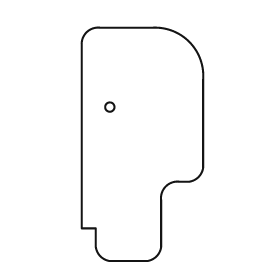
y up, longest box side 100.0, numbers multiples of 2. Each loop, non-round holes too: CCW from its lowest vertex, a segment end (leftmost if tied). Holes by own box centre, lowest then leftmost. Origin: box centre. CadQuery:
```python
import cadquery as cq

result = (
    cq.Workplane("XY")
    .moveTo(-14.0, -50.0)
    .lineTo(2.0, -50.0)
    .threePointArc((6.0, -48.0), (8.0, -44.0))
    .lineTo(8.0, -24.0)
    .threePointArc((10.0, -18.0), (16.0, -16.0))
    .lineTo(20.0, -16.0)
    .threePointArc((24.0, -14.0), (26.0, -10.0))
    .lineTo(26.0, 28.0)
    .threePointArc((20.0, 44.0), (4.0, 50.0))
    .lineTo(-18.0, 50.0)
    .threePointArc((-24.0, 48.0), (-26.0, 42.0))
    .lineTo(-26.0, -36.0)
    .lineTo(-20.0, -36.0)
    .lineTo(-20.0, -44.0)
    .threePointArc((-18.0, -48.0), (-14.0, -50.0))
    .close()
    .moveTo(-14.0, 16.0)
    .circle(2.0)
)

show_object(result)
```